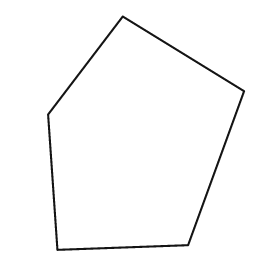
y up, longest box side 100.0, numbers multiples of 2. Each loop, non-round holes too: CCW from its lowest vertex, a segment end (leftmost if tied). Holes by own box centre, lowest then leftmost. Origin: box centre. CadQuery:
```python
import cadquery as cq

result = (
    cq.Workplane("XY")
    .moveTo(-38.0, -50.0)
    .lineTo(18.0, -48.0)
    .lineTo(42.0, 18.0)
    .lineTo(-10.0, 50.0)
    .lineTo(-42.0, 8.0)
    .close()
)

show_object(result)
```